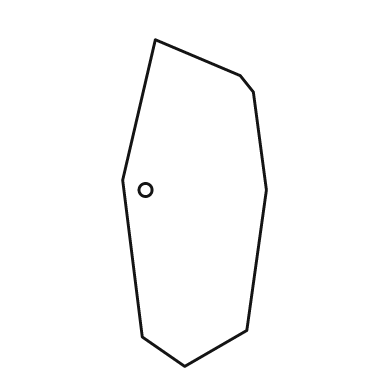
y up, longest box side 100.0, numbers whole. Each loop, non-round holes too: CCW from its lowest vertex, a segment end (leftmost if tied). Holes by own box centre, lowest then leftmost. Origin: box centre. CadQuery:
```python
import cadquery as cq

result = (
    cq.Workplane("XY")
    .moveTo(-3.0, -50.0)
    .lineTo(16.0, -39.0)
    .lineTo(22.0, 4.0)
    .lineTo(18.0, 34.0)
    .lineTo(14.0, 39.0)
    .lineTo(-12.0, 50.0)
    .lineTo(-22.0, 7.0)
    .lineTo(-16.0, -41.0)
    .close()
    .moveTo(-15.0, 4.0)
    .circle(2.0)
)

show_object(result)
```